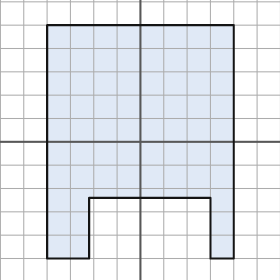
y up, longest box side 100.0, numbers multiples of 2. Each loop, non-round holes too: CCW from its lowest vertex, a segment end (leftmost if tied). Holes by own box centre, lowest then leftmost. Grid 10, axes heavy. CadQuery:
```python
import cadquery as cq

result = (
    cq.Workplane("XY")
    .moveTo(-40.0, -50.0)
    .lineTo(-22.0, -50.0)
    .lineTo(-22.0, -24.0)
    .lineTo(30.0, -24.0)
    .lineTo(30.0, -50.0)
    .lineTo(40.0, -50.0)
    .lineTo(40.0, 50.0)
    .lineTo(-40.0, 50.0)
    .close()
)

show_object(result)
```